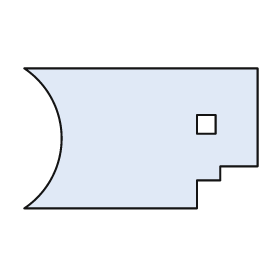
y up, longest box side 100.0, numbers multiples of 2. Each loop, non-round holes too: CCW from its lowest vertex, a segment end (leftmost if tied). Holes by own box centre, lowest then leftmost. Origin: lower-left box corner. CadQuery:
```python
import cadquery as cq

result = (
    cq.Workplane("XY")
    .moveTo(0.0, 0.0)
    .lineTo(74.0, 0.0)
    .lineTo(74.0, 12.0)
    .lineTo(84.0, 12.0)
    .lineTo(84.0, 18.0)
    .lineTo(100.0, 18.0)
    .lineTo(100.0, 60.0)
    .lineTo(0.0, 60.0)
    .threePointArc((16.0, 30.0), (0.0, 0.0))
    .close()
    .moveTo(74.0, 32.0)
    .lineTo(82.0, 32.0)
    .lineTo(82.0, 40.0)
    .lineTo(74.0, 40.0)
    .close()
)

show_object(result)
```